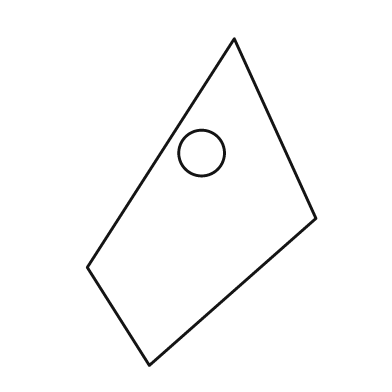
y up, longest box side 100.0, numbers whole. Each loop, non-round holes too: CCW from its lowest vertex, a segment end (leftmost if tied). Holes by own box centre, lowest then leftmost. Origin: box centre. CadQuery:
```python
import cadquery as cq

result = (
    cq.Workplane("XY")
    .moveTo(-16.0, -50.0)
    .lineTo(35.0, -5.0)
    .lineTo(10.0, 50.0)
    .lineTo(-35.0, -20.0)
    .close()
    .moveTo(0.0, 15.0)
    .circle(7.0)
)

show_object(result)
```